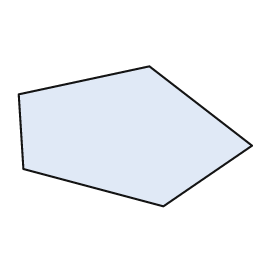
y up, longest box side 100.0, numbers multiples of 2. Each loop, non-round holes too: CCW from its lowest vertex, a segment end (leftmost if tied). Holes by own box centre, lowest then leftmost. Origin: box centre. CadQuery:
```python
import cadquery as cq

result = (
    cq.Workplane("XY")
    .moveTo(12.0, -30.0)
    .lineTo(50.0, -4.0)
    .lineTo(6.0, 30.0)
    .lineTo(-50.0, 18.0)
    .lineTo(-48.0, -14.0)
    .close()
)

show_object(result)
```